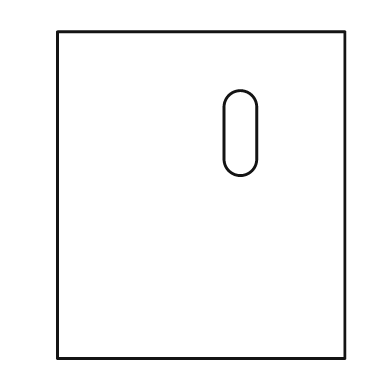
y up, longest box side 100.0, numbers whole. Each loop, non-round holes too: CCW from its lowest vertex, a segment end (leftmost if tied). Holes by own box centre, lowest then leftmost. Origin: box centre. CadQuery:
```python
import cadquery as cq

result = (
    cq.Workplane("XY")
    .moveTo(-44.0, -50.0)
    .lineTo(44.0, -50.0)
    .lineTo(44.0, 50.0)
    .lineTo(-44.0, 50.0)
    .close()
    .moveTo(7.0, 11.0)
    .threePointArc((12.0, 6.0), (17.0, 11.0))
    .lineTo(17.0, 27.0)
    .threePointArc((12.0, 32.0), (7.0, 27.0))
    .close()
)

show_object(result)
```